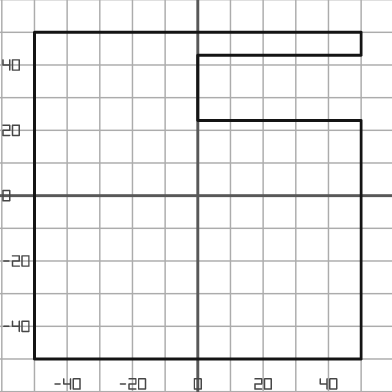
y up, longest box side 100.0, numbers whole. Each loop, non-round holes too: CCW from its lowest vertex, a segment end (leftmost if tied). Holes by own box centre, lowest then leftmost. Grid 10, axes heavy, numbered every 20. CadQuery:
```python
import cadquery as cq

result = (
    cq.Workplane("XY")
    .moveTo(-50.0, -50.0)
    .lineTo(50.0, -50.0)
    .lineTo(50.0, 23.0)
    .lineTo(0.0, 23.0)
    .lineTo(0.0, 43.0)
    .lineTo(50.0, 43.0)
    .lineTo(50.0, 50.0)
    .lineTo(-50.0, 50.0)
    .close()
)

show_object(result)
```